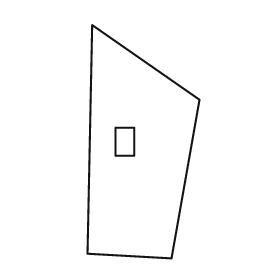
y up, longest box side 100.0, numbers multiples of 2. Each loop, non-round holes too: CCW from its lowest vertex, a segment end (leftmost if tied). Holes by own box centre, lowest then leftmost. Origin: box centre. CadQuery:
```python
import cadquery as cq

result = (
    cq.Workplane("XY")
    .moveTo(12.0, -50.0)
    .lineTo(24.0, 18.0)
    .lineTo(-22.0, 50.0)
    .lineTo(-24.0, -48.0)
    .close()
    .moveTo(-12.0, -6.0)
    .lineTo(-4.0, -6.0)
    .lineTo(-4.0, 6.0)
    .lineTo(-12.0, 6.0)
    .close()
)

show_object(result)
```